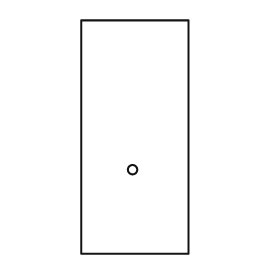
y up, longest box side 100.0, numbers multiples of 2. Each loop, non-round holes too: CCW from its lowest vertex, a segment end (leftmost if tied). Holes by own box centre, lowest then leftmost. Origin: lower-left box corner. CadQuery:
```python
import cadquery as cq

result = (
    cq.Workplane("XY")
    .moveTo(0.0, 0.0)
    .lineTo(46.0, 0.0)
    .lineTo(46.0, 100.0)
    .lineTo(0.0, 100.0)
    .close()
    .moveTo(22.0, 36.0)
    .circle(2.0)
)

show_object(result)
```